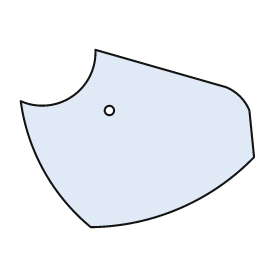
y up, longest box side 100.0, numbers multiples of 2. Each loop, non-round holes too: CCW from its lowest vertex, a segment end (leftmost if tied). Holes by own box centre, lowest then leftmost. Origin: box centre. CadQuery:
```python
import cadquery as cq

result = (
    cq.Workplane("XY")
    .moveTo(-20.0, -38.0)
    .threePointArc((18.0, -30.0), (50.0, -8.0))
    .lineTo(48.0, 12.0)
    .threePointArc((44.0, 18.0), (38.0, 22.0))
    .lineTo(-18.0, 38.0)
    .threePointArc((-28.0, 18.0), (-50.0, 16.0))
    .threePointArc((-40.0, -14.0), (-20.0, -38.0))
    .close()
    .moveTo(-12.0, 12.0)
    .circle(2.0)
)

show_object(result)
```